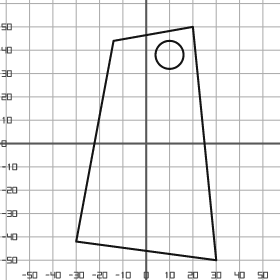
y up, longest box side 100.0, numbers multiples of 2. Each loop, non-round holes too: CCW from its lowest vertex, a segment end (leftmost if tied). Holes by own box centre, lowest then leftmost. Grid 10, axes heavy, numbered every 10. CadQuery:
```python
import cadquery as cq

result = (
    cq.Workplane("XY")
    .moveTo(30.0, -50.0)
    .lineTo(20.0, 50.0)
    .lineTo(-14.0, 44.0)
    .lineTo(-30.0, -42.0)
    .close()
    .moveTo(10.0, 38.0)
    .circle(6.0)
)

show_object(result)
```